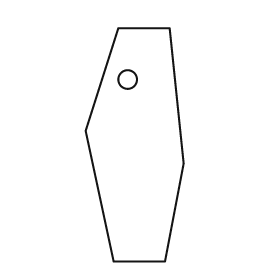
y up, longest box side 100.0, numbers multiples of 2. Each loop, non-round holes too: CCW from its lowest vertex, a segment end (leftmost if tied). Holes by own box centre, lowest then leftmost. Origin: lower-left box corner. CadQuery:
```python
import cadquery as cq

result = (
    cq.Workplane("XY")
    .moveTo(12.0, 0.0)
    .lineTo(34.0, 0.0)
    .lineTo(42.0, 42.0)
    .lineTo(36.0, 100.0)
    .lineTo(14.0, 100.0)
    .lineTo(0.0, 56.0)
    .close()
    .moveTo(18.0, 78.0)
    .circle(4.0)
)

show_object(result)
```